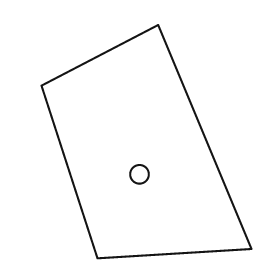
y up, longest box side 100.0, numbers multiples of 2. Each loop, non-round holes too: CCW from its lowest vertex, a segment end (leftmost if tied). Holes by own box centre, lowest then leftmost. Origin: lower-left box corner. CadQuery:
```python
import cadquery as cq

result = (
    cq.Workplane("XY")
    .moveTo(24.0, 0.0)
    .lineTo(90.0, 4.0)
    .lineTo(50.0, 100.0)
    .lineTo(0.0, 74.0)
    .close()
    .moveTo(42.0, 36.0)
    .circle(4.0)
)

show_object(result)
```